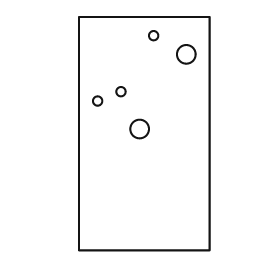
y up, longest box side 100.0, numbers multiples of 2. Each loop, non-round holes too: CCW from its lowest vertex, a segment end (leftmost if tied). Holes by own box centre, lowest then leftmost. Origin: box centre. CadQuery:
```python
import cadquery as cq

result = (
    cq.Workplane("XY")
    .moveTo(-28.0, -50.0)
    .lineTo(28.0, -50.0)
    .lineTo(28.0, 50.0)
    .lineTo(-28.0, 50.0)
    .close()
    .moveTo(-2.0, 2.0)
    .circle(4.0)
    .moveTo(-20.0, 14.0)
    .circle(2.0)
    .moveTo(-10.0, 18.0)
    .circle(2.0)
    .moveTo(18.0, 34.0)
    .circle(4.0)
    .moveTo(4.0, 42.0)
    .circle(2.0)
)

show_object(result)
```